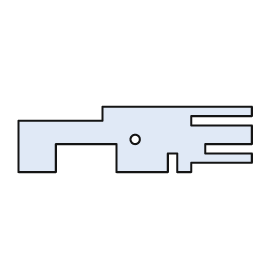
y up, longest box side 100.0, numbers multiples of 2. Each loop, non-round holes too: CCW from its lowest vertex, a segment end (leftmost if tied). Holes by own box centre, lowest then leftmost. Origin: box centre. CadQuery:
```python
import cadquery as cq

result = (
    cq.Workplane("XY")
    .moveTo(-50.0, -14.0)
    .lineTo(-34.0, -14.0)
    .lineTo(-34.0, -2.0)
    .lineTo(-8.0, -2.0)
    .lineTo(-8.0, -14.0)
    .lineTo(14.0, -14.0)
    .lineTo(14.0, -6.0)
    .lineTo(18.0, -6.0)
    .lineTo(18.0, -14.0)
    .lineTo(24.0, -14.0)
    .lineTo(24.0, -10.0)
    .lineTo(50.0, -10.0)
    .lineTo(50.0, -6.0)
    .lineTo(30.0, -6.0)
    .lineTo(30.0, -2.0)
    .lineTo(50.0, -2.0)
    .lineTo(50.0, 6.0)
    .lineTo(24.0, 6.0)
    .lineTo(24.0, 10.0)
    .lineTo(50.0, 10.0)
    .lineTo(50.0, 14.0)
    .lineTo(-14.0, 14.0)
    .lineTo(-14.0, 8.0)
    .lineTo(-50.0, 8.0)
    .close()
    .moveTo(0.0, 0.0)
    .circle(2.0)
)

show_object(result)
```